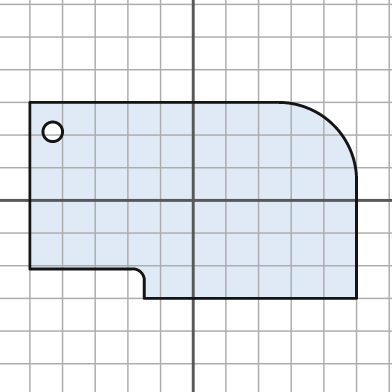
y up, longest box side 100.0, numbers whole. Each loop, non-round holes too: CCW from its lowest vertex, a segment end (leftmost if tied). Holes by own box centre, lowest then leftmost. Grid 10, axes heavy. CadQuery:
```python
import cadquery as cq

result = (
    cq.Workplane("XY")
    .moveTo(-15.0, -30.0)
    .lineTo(50.0, -30.0)
    .lineTo(50.0, 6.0)
    .threePointArc((43.0, 23.0), (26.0, 30.0))
    .lineTo(-50.0, 30.0)
    .lineTo(-50.0, -21.0)
    .lineTo(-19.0, -21.0)
    .threePointArc((-16.0, -22.0), (-15.0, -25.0))
    .close()
    .moveTo(-43.0, 21.0)
    .circle(3.0)
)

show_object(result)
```